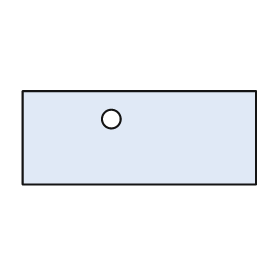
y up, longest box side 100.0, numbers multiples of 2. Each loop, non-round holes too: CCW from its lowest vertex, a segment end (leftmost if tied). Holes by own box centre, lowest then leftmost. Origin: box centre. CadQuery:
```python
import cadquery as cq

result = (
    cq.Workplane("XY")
    .moveTo(-50.0, -20.0)
    .lineTo(50.0, -20.0)
    .lineTo(50.0, 20.0)
    .lineTo(-50.0, 20.0)
    .close()
    .moveTo(-12.0, 8.0)
    .circle(4.0)
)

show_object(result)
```